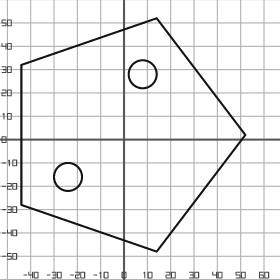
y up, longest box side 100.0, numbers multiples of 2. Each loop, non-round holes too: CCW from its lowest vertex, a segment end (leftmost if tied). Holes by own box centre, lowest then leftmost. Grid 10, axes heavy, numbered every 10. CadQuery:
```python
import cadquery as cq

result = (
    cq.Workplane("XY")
    .moveTo(14.0, -48.0)
    .lineTo(52.0, 2.0)
    .lineTo(14.0, 52.0)
    .lineTo(-44.0, 32.0)
    .lineTo(-44.0, -28.0)
    .close()
    .moveTo(-24.0, -16.0)
    .circle(6.0)
    .moveTo(8.0, 28.0)
    .circle(6.0)
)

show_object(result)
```